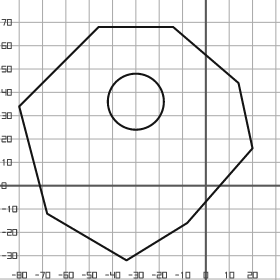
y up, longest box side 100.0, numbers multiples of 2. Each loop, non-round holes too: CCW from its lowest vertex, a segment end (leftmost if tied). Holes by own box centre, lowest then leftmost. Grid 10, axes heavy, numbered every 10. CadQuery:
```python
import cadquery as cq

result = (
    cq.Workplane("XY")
    .moveTo(-34.0, -32.0)
    .lineTo(-8.0, -16.0)
    .lineTo(20.0, 16.0)
    .lineTo(14.0, 44.0)
    .lineTo(-14.0, 68.0)
    .lineTo(-46.0, 68.0)
    .lineTo(-80.0, 34.0)
    .lineTo(-68.0, -12.0)
    .close()
    .moveTo(-30.0, 36.0)
    .circle(12.0)
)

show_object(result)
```